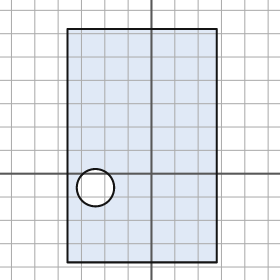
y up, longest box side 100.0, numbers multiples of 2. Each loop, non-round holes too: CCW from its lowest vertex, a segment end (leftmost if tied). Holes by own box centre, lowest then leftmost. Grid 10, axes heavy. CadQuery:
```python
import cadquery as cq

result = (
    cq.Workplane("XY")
    .moveTo(-36.0, -38.0)
    .lineTo(28.0, -38.0)
    .lineTo(28.0, 62.0)
    .lineTo(-36.0, 62.0)
    .close()
    .moveTo(-24.0, -6.0)
    .circle(8.0)
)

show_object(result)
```